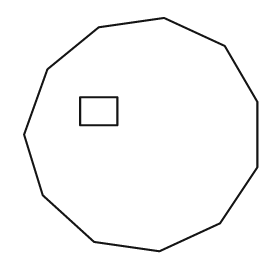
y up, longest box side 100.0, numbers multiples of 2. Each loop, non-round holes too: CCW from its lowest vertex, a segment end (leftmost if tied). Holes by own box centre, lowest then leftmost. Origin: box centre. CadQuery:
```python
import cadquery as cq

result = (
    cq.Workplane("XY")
    .moveTo(8.0, -50.0)
    .lineTo(34.0, -38.0)
    .lineTo(50.0, -14.0)
    .lineTo(50.0, 14.0)
    .lineTo(36.0, 38.0)
    .lineTo(10.0, 50.0)
    .lineTo(-18.0, 46.0)
    .lineTo(-40.0, 28.0)
    .lineTo(-50.0, 0.0)
    .lineTo(-42.0, -26.0)
    .lineTo(-20.0, -46.0)
    .close()
    .moveTo(-26.0, 4.0)
    .lineTo(-10.0, 4.0)
    .lineTo(-10.0, 16.0)
    .lineTo(-26.0, 16.0)
    .close()
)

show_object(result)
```